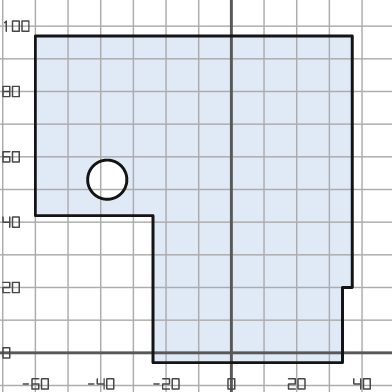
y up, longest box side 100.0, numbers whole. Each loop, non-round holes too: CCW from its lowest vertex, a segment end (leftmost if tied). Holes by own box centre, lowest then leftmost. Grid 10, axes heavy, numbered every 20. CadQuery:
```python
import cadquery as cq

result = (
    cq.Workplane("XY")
    .moveTo(-24.0, -3.0)
    .lineTo(34.0, -3.0)
    .lineTo(34.0, 20.0)
    .lineTo(37.0, 20.0)
    .lineTo(37.0, 97.0)
    .lineTo(-60.0, 97.0)
    .lineTo(-60.0, 42.0)
    .lineTo(-24.0, 42.0)
    .close()
    .moveTo(-38.0, 53.0)
    .circle(6.0)
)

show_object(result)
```